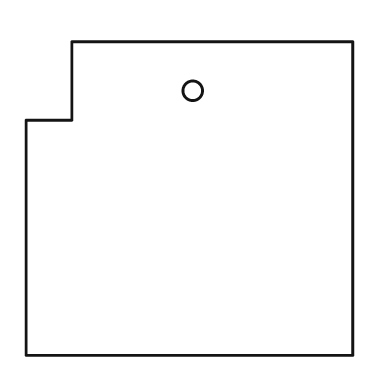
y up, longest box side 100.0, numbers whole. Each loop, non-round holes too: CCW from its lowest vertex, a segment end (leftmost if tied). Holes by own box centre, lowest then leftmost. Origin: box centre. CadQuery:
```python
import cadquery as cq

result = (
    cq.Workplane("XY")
    .moveTo(-50.0, -48.0)
    .lineTo(50.0, -48.0)
    .lineTo(50.0, 48.0)
    .lineTo(-36.0, 48.0)
    .lineTo(-36.0, 24.0)
    .lineTo(-50.0, 24.0)
    .close()
    .moveTo(1.0, 33.0)
    .circle(3.0)
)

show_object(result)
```